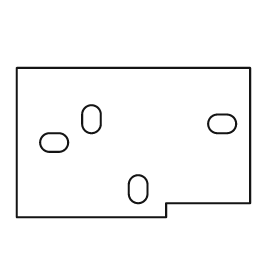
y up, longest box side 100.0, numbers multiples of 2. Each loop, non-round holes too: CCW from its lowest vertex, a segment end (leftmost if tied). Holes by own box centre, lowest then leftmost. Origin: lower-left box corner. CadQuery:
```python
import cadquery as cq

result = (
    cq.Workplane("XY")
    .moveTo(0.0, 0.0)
    .lineTo(64.0, 0.0)
    .lineTo(64.0, 6.0)
    .lineTo(100.0, 6.0)
    .lineTo(100.0, 64.0)
    .lineTo(0.0, 64.0)
    .close()
    .moveTo(48.0, 10.0)
    .threePointArc((52.0, 6.0), (56.0, 10.0))
    .lineTo(56.0, 14.0)
    .threePointArc((52.0, 18.0), (48.0, 14.0))
    .close()
    .moveTo(14.0, 28.0)
    .lineTo(18.0, 28.0)
    .threePointArc((22.0, 32.0), (18.0, 36.0))
    .lineTo(14.0, 36.0)
    .threePointArc((10.0, 32.0), (14.0, 28.0))
    .close()
    .moveTo(86.0, 36.0)
    .lineTo(90.0, 36.0)
    .threePointArc((94.0, 40.0), (90.0, 44.0))
    .lineTo(86.0, 44.0)
    .threePointArc((82.0, 40.0), (86.0, 36.0))
    .close()
    .moveTo(28.0, 40.0)
    .threePointArc((32.0, 36.0), (36.0, 40.0))
    .lineTo(36.0, 44.0)
    .threePointArc((32.0, 48.0), (28.0, 44.0))
    .close()
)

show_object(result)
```